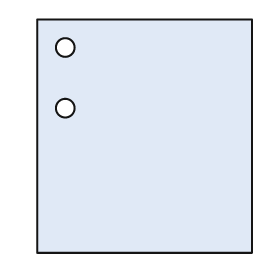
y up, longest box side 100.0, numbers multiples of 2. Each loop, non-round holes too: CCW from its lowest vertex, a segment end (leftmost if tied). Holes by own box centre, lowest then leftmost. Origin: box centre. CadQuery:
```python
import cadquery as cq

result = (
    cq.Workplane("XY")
    .moveTo(-46.0, -50.0)
    .lineTo(46.0, -50.0)
    .lineTo(46.0, 50.0)
    .lineTo(-46.0, 50.0)
    .close()
    .moveTo(-34.0, 12.0)
    .circle(4.0)
    .moveTo(-34.0, 38.0)
    .circle(4.0)
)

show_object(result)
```